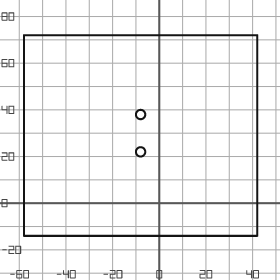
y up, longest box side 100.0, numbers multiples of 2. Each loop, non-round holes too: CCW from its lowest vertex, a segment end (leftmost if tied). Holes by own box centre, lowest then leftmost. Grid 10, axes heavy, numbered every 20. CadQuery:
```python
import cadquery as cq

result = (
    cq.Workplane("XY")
    .moveTo(-58.0, -14.0)
    .lineTo(42.0, -14.0)
    .lineTo(42.0, 72.0)
    .lineTo(-58.0, 72.0)
    .close()
    .moveTo(-8.0, 22.0)
    .circle(2.0)
    .moveTo(-8.0, 38.0)
    .circle(2.0)
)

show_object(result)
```